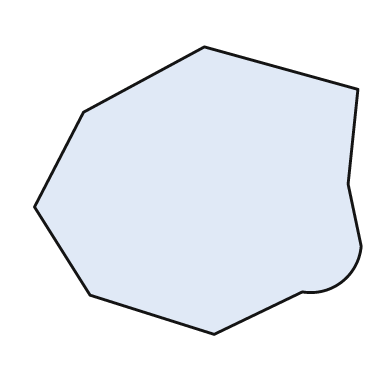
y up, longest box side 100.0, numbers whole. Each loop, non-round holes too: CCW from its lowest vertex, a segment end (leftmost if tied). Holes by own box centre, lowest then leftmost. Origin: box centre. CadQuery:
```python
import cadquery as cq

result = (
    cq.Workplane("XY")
    .moveTo(5.0, -44.0)
    .lineTo(32.0, -31.0)
    .threePointArc((44.0, -28.0), (50.0, -17.0))
    .lineTo(46.0, 2.0)
    .lineTo(49.0, 31.0)
    .lineTo(2.0, 44.0)
    .lineTo(-35.0, 24.0)
    .lineTo(-50.0, -5.0)
    .lineTo(-33.0, -32.0)
    .close()
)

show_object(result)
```